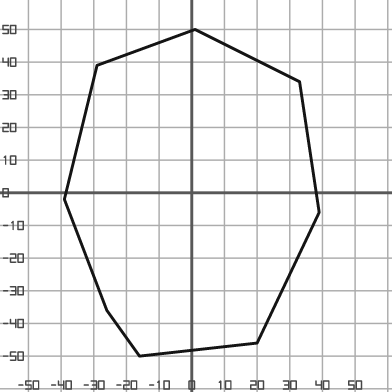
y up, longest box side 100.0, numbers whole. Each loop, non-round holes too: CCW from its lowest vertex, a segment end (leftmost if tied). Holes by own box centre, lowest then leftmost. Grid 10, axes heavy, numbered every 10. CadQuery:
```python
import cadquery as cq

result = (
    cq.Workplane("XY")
    .moveTo(-16.0, -50.0)
    .lineTo(20.0, -46.0)
    .lineTo(39.0, -6.0)
    .lineTo(33.0, 34.0)
    .lineTo(1.0, 50.0)
    .lineTo(-29.0, 39.0)
    .lineTo(-39.0, -2.0)
    .lineTo(-26.0, -36.0)
    .close()
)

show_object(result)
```